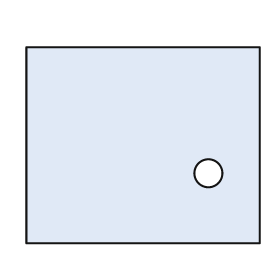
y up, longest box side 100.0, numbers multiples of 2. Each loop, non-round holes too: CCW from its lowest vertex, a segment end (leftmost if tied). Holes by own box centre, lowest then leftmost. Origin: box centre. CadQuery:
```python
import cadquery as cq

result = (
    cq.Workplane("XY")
    .moveTo(-50.0, -42.0)
    .lineTo(50.0, -42.0)
    .lineTo(50.0, 42.0)
    .lineTo(-50.0, 42.0)
    .close()
    .moveTo(28.0, -12.0)
    .circle(6.0)
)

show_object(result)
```